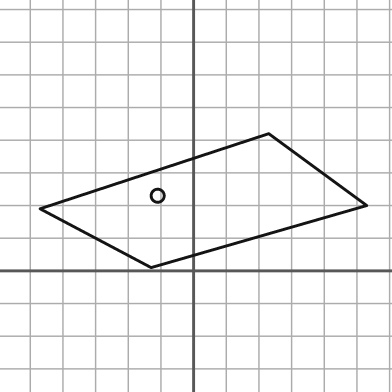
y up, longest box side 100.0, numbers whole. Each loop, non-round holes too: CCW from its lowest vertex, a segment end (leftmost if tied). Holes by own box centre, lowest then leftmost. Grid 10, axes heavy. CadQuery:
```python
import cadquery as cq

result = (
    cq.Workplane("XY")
    .moveTo(-13.0, 1.0)
    .lineTo(53.0, 20.0)
    .lineTo(23.0, 42.0)
    .lineTo(-47.0, 19.0)
    .close()
    .moveTo(-11.0, 23.0)
    .circle(2.0)
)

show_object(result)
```